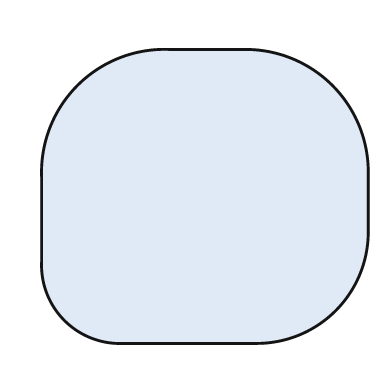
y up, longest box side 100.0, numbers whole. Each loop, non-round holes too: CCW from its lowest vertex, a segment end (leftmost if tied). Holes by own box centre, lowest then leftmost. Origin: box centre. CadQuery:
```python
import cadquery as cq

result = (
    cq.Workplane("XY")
    .moveTo(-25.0, -45.0)
    .lineTo(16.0, -45.0)
    .threePointArc((40.0, -35.0), (50.0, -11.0))
    .lineTo(50.0, 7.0)
    .threePointArc((39.0, 34.0), (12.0, 45.0))
    .lineTo(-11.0, 45.0)
    .threePointArc((-39.0, 34.0), (-50.0, 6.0))
    .lineTo(-50.0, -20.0)
    .threePointArc((-43.0, -38.0), (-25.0, -45.0))
    .close()
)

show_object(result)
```